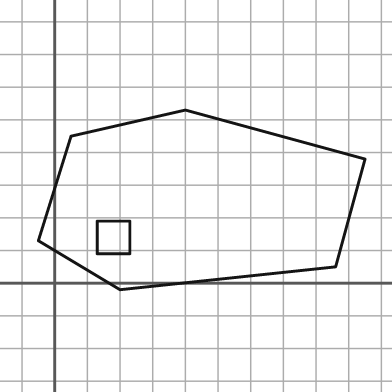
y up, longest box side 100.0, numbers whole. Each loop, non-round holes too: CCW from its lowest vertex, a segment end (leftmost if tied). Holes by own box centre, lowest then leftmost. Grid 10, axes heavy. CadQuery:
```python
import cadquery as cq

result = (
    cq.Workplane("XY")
    .moveTo(20.0, -2.0)
    .lineTo(86.0, 5.0)
    .lineTo(95.0, 38.0)
    .lineTo(40.0, 53.0)
    .lineTo(5.0, 45.0)
    .lineTo(-5.0, 13.0)
    .close()
    .moveTo(13.0, 9.0)
    .lineTo(23.0, 9.0)
    .lineTo(23.0, 19.0)
    .lineTo(13.0, 19.0)
    .close()
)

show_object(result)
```